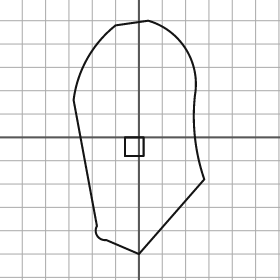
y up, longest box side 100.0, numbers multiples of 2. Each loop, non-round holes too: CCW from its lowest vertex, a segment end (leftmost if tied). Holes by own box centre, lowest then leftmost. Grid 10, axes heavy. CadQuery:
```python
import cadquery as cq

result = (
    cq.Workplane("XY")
    .moveTo(0.0, -50.0)
    .lineTo(28.0, -18.0)
    .threePointArc((24.0, 0.0), (24.0, 18.0))
    .threePointArc((20.0, 38.0), (4.0, 50.0))
    .lineTo(-10.0, 48.0)
    .threePointArc((-22.0, 34.0), (-28.0, 16.0))
    .lineTo(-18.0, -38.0)
    .threePointArc((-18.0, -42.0), (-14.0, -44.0))
    .close()
    .moveTo(-6.0, -8.0)
    .lineTo(2.0, -8.0)
    .lineTo(2.0, 0.0)
    .lineTo(-6.0, 0.0)
    .close()
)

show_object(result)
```